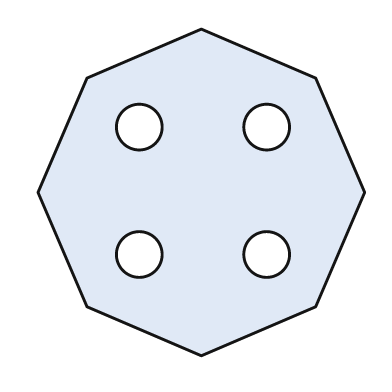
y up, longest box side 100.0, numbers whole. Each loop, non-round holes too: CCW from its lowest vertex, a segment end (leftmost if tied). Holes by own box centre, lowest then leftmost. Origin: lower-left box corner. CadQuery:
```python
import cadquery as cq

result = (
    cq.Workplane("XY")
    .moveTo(50.0, 0.0)
    .lineTo(85.0, 15.0)
    .lineTo(100.0, 50.0)
    .lineTo(85.0, 85.0)
    .lineTo(50.0, 100.0)
    .lineTo(15.0, 85.0)
    .lineTo(0.0, 50.0)
    .lineTo(15.0, 15.0)
    .close()
    .moveTo(31.0, 31.0)
    .circle(7.0)
    .moveTo(70.0, 31.0)
    .circle(7.0)
    .moveTo(31.0, 70.0)
    .circle(7.0)
    .moveTo(70.0, 70.0)
    .circle(7.0)
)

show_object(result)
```